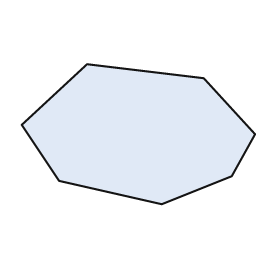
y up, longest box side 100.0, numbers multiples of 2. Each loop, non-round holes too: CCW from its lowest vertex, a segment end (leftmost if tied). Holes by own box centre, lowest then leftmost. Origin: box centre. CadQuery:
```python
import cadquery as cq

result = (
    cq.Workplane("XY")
    .moveTo(10.0, -30.0)
    .lineTo(40.0, -18.0)
    .lineTo(50.0, 0.0)
    .lineTo(28.0, 24.0)
    .lineTo(-22.0, 30.0)
    .lineTo(-50.0, 4.0)
    .lineTo(-34.0, -20.0)
    .close()
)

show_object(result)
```